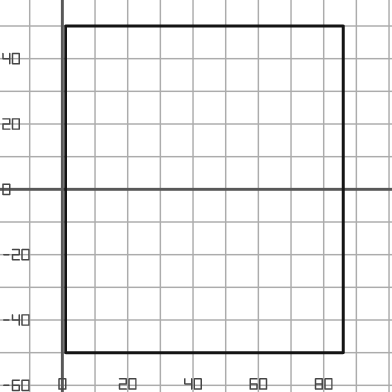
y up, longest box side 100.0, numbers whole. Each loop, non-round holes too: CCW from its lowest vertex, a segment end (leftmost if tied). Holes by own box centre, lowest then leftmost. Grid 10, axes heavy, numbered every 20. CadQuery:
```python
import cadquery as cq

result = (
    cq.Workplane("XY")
    .moveTo(1.0, -50.0)
    .lineTo(86.0, -50.0)
    .lineTo(86.0, 50.0)
    .lineTo(1.0, 50.0)
    .close()
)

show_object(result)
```